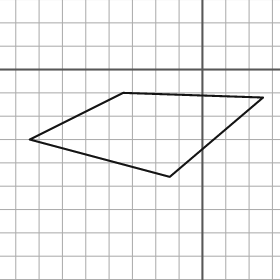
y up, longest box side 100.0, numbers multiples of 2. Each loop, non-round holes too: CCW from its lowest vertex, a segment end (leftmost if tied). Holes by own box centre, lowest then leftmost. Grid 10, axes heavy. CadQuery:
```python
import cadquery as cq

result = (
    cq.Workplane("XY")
    .moveTo(-14.0, -46.0)
    .lineTo(26.0, -12.0)
    .lineTo(-34.0, -10.0)
    .lineTo(-74.0, -30.0)
    .close()
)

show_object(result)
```